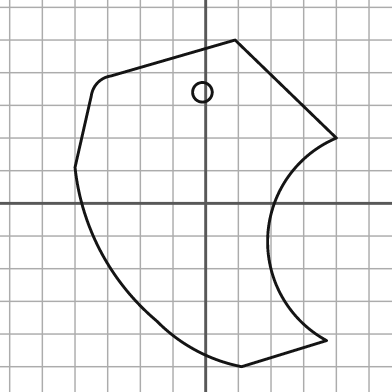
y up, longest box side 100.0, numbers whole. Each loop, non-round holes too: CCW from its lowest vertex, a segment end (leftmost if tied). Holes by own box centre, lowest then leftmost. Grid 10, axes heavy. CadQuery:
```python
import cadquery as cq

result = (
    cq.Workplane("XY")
    .moveTo(11.0, -50.0)
    .lineTo(37.0, -42.0)
    .threePointArc((19.0, -10.0), (40.0, 20.0))
    .lineTo(9.0, 50.0)
    .lineTo(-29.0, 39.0)
    .threePointArc((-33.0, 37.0), (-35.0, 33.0))
    .lineTo(-40.0, 11.0)
    .threePointArc((-32.0, -15.0), (-15.0, -36.0))
    .threePointArc((-3.0, -45.0), (11.0, -50.0))
    .close()
    .moveTo(-1.0, 34.0)
    .circle(3.0)
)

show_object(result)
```